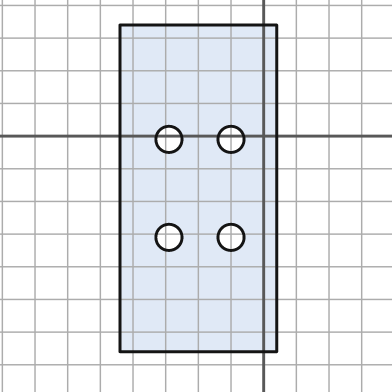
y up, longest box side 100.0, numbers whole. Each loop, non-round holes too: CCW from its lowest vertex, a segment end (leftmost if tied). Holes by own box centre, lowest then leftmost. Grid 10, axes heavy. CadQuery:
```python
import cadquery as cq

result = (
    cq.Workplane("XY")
    .moveTo(-44.0, -66.0)
    .lineTo(4.0, -66.0)
    .lineTo(4.0, 34.0)
    .lineTo(-44.0, 34.0)
    .close()
    .moveTo(-29.0, -31.0)
    .circle(4.0)
    .moveTo(-10.0, -31.0)
    .circle(4.0)
    .moveTo(-29.0, -1.0)
    .circle(4.0)
    .moveTo(-10.0, -1.0)
    .circle(4.0)
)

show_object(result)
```